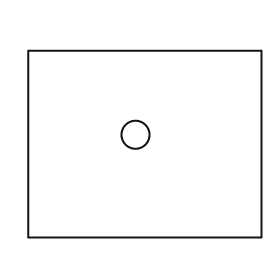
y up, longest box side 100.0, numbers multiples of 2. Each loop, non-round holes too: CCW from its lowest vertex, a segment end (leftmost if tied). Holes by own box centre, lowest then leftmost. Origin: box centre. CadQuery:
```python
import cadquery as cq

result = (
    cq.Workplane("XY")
    .moveTo(-50.0, -40.0)
    .lineTo(50.0, -40.0)
    .lineTo(50.0, 40.0)
    .lineTo(-50.0, 40.0)
    .close()
    .moveTo(-4.0, 4.0)
    .circle(6.0)
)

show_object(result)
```